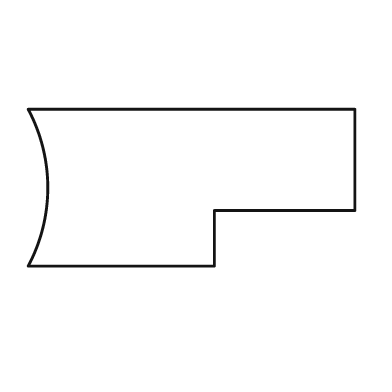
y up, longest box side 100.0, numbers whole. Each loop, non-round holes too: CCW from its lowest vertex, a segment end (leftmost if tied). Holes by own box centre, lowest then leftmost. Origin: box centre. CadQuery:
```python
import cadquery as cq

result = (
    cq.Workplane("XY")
    .moveTo(-50.0, -24.0)
    .lineTo(7.0, -24.0)
    .lineTo(7.0, -7.0)
    .lineTo(50.0, -7.0)
    .lineTo(50.0, 24.0)
    .lineTo(-50.0, 24.0)
    .threePointArc((-44.0, 0.0), (-50.0, -24.0))
    .close()
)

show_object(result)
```